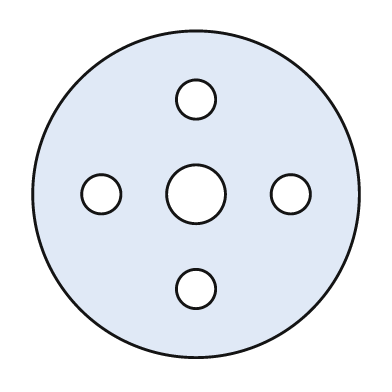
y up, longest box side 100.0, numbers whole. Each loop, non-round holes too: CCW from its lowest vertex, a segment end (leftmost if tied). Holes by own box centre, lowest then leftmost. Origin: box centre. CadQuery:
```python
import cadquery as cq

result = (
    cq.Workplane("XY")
    .moveTo(0.0, 0.0)
    .circle(50.0)
    .moveTo(0.0, -29.0)
    .circle(6.0)
    .moveTo(-29.0, 0.0)
    .circle(6.0)
    .moveTo(0.0, 0.0)
    .circle(9.0)
    .moveTo(29.0, 0.0)
    .circle(6.0)
    .moveTo(0.0, 29.0)
    .circle(6.0)
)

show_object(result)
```